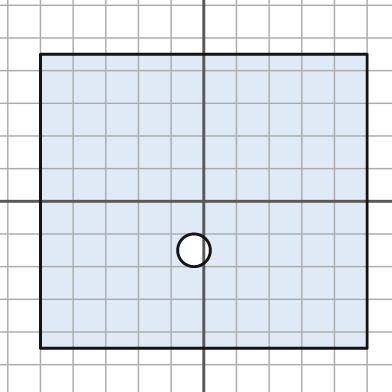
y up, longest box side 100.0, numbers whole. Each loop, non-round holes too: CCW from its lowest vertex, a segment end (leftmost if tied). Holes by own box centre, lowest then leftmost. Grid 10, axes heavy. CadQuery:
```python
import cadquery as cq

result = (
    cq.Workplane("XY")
    .moveTo(-50.0, -45.0)
    .lineTo(50.0, -45.0)
    .lineTo(50.0, 45.0)
    .lineTo(-50.0, 45.0)
    .close()
    .moveTo(-3.0, -15.0)
    .circle(5.0)
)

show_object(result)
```